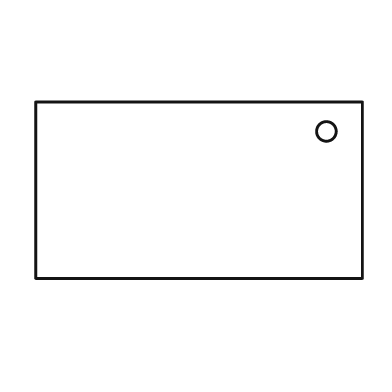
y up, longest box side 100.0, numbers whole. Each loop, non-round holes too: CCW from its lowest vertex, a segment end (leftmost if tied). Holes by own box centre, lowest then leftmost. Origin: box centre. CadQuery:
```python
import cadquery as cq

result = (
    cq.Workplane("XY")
    .moveTo(-50.0, -27.0)
    .lineTo(50.0, -27.0)
    .lineTo(50.0, 27.0)
    .lineTo(-50.0, 27.0)
    .close()
    .moveTo(39.0, 18.0)
    .circle(3.0)
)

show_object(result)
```